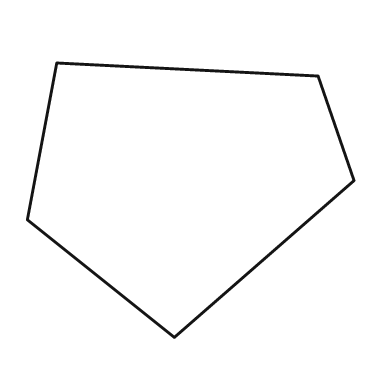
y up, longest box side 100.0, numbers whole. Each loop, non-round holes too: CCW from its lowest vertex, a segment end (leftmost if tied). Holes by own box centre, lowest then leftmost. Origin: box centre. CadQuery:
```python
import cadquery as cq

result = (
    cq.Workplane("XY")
    .moveTo(-5.0, -42.0)
    .lineTo(50.0, 6.0)
    .lineTo(39.0, 38.0)
    .lineTo(-41.0, 42.0)
    .lineTo(-50.0, -6.0)
    .close()
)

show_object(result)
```